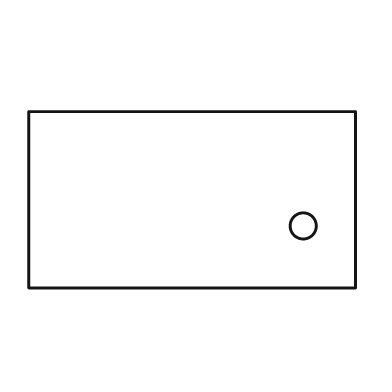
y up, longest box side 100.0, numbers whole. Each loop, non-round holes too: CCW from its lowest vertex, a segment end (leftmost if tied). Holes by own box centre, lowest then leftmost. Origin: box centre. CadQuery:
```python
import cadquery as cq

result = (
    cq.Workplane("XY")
    .moveTo(-50.0, -27.0)
    .lineTo(50.0, -27.0)
    .lineTo(50.0, 27.0)
    .lineTo(-50.0, 27.0)
    .close()
    .moveTo(34.0, -8.0)
    .circle(4.0)
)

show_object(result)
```